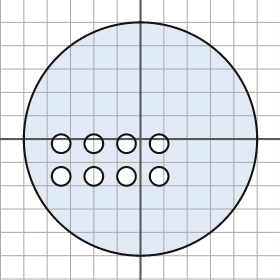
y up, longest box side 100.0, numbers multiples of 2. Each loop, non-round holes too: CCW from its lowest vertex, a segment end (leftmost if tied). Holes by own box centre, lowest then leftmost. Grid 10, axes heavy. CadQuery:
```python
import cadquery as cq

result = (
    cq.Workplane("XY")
    .moveTo(0.0, 0.0)
    .circle(50.0)
    .moveTo(-34.0, -16.0)
    .circle(4.0)
    .moveTo(-20.0, -16.0)
    .circle(4.0)
    .moveTo(-6.0, -16.0)
    .circle(4.0)
    .moveTo(8.0, -16.0)
    .circle(4.0)
    .moveTo(-34.0, -2.0)
    .circle(4.0)
    .moveTo(-20.0, -2.0)
    .circle(4.0)
    .moveTo(-6.0, -2.0)
    .circle(4.0)
    .moveTo(8.0, -2.0)
    .circle(4.0)
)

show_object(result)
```